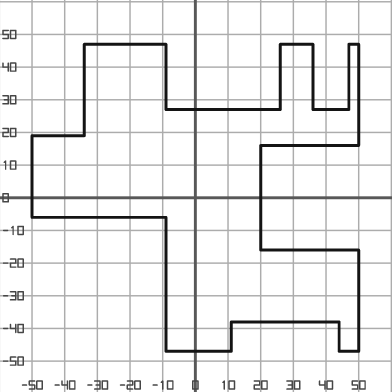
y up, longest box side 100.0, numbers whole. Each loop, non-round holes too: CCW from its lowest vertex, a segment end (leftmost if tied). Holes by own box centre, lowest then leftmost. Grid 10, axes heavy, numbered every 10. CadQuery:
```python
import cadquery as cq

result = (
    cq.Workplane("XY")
    .moveTo(-9.0, -47.0)
    .lineTo(11.0, -47.0)
    .lineTo(11.0, -38.0)
    .lineTo(44.0, -38.0)
    .lineTo(44.0, -47.0)
    .lineTo(50.0, -47.0)
    .lineTo(50.0, -16.0)
    .lineTo(20.0, -16.0)
    .lineTo(20.0, 16.0)
    .lineTo(50.0, 16.0)
    .lineTo(50.0, 47.0)
    .lineTo(47.0, 47.0)
    .lineTo(47.0, 27.0)
    .lineTo(36.0, 27.0)
    .lineTo(36.0, 47.0)
    .lineTo(26.0, 47.0)
    .lineTo(26.0, 27.0)
    .lineTo(-9.0, 27.0)
    .lineTo(-9.0, 47.0)
    .lineTo(-34.0, 47.0)
    .lineTo(-34.0, 19.0)
    .lineTo(-50.0, 19.0)
    .lineTo(-50.0, -6.0)
    .lineTo(-9.0, -6.0)
    .close()
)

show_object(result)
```